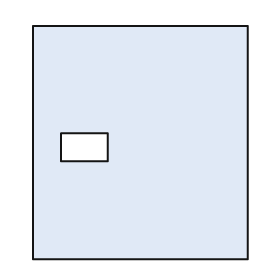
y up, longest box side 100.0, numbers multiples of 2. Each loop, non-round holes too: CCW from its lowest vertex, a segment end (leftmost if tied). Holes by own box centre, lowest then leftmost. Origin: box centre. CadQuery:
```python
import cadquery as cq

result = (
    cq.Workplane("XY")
    .moveTo(-46.0, -50.0)
    .lineTo(46.0, -50.0)
    .lineTo(46.0, 50.0)
    .lineTo(-46.0, 50.0)
    .close()
    .moveTo(-34.0, -8.0)
    .lineTo(-14.0, -8.0)
    .lineTo(-14.0, 4.0)
    .lineTo(-34.0, 4.0)
    .close()
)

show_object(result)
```